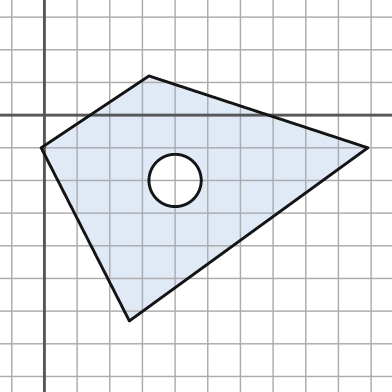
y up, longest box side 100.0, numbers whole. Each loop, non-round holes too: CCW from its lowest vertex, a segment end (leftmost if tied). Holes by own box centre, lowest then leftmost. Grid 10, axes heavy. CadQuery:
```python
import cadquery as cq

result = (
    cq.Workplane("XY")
    .moveTo(26.0, -63.0)
    .lineTo(99.0, -10.0)
    .lineTo(32.0, 12.0)
    .lineTo(-1.0, -10.0)
    .close()
    .moveTo(40.0, -20.0)
    .circle(8.0)
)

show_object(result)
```